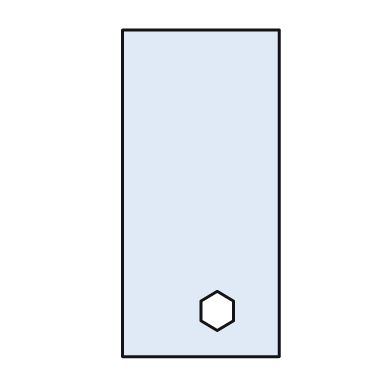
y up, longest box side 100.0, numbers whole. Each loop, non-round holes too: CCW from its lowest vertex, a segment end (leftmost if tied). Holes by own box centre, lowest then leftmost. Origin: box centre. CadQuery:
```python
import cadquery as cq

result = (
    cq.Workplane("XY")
    .moveTo(-24.0, -50.0)
    .lineTo(24.0, -50.0)
    .lineTo(24.0, 50.0)
    .lineTo(-24.0, 50.0)
    .close()
    .moveTo(5.0, -42.0)
    .lineTo(10.0, -39.0)
    .lineTo(10.0, -33.0)
    .lineTo(5.0, -30.0)
    .lineTo(0.0, -33.0)
    .lineTo(0.0, -39.0)
    .close()
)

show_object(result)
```